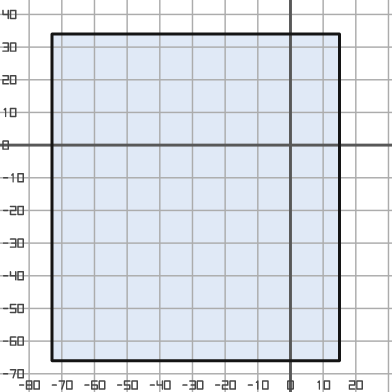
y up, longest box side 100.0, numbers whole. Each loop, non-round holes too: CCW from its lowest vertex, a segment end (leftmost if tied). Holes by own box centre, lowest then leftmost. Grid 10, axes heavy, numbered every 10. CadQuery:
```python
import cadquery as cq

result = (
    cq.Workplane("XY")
    .moveTo(-73.0, -66.0)
    .lineTo(15.0, -66.0)
    .lineTo(15.0, 34.0)
    .lineTo(-73.0, 34.0)
    .close()
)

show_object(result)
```